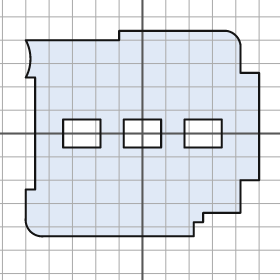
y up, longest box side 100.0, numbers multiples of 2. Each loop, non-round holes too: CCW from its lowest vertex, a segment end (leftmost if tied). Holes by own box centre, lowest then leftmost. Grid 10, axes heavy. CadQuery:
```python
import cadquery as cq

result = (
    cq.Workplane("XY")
    .moveTo(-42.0, -44.0)
    .lineTo(22.0, -44.0)
    .lineTo(22.0, -38.0)
    .lineTo(26.0, -38.0)
    .lineTo(26.0, -34.0)
    .lineTo(42.0, -34.0)
    .lineTo(42.0, -20.0)
    .lineTo(50.0, -20.0)
    .lineTo(50.0, 26.0)
    .lineTo(42.0, 26.0)
    .lineTo(42.0, 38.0)
    .threePointArc((40.0, 42.0), (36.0, 44.0))
    .lineTo(-10.0, 44.0)
    .lineTo(-10.0, 40.0)
    .lineTo(-50.0, 40.0)
    .threePointArc((-48.0, 32.0), (-50.0, 24.0))
    .lineTo(-46.0, 24.0)
    .lineTo(-46.0, -24.0)
    .lineTo(-50.0, -24.0)
    .lineTo(-50.0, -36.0)
    .threePointArc((-48.0, -42.0), (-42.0, -44.0))
    .close()
    .moveTo(-34.0, -6.0)
    .lineTo(-18.0, -6.0)
    .lineTo(-18.0, 6.0)
    .lineTo(-34.0, 6.0)
    .close()
    .moveTo(-8.0, -6.0)
    .lineTo(8.0, -6.0)
    .lineTo(8.0, 6.0)
    .lineTo(-8.0, 6.0)
    .close()
    .moveTo(18.0, -6.0)
    .lineTo(34.0, -6.0)
    .lineTo(34.0, 6.0)
    .lineTo(18.0, 6.0)
    .close()
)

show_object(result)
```